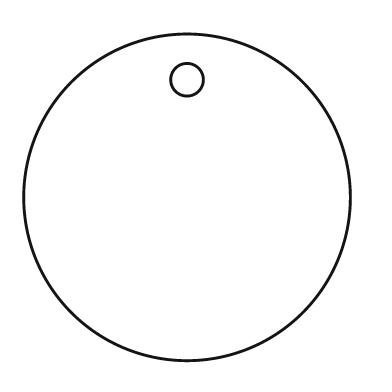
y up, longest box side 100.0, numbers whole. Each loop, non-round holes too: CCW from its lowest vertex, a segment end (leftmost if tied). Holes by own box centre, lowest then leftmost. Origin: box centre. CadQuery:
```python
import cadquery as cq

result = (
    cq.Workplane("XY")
    .moveTo(0.0, 0.0)
    .circle(50.0)
    .moveTo(0.0, 36.0)
    .circle(5.0)
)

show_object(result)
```